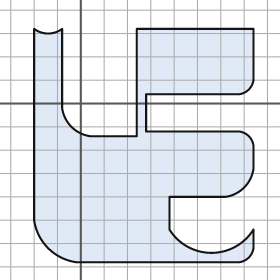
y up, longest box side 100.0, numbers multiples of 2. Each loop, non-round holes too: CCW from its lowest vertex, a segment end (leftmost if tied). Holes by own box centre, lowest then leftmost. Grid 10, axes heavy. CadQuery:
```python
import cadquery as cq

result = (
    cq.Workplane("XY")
    .moveTo(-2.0, -68.0)
    .lineTo(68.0, -68.0)
    .threePointArc((72.0, -66.0), (74.0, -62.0))
    .lineTo(74.0, -54.0)
    .threePointArc((56.0, -64.0), (38.0, -54.0))
    .lineTo(38.0, -40.0)
    .lineTo(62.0, -40.0)
    .threePointArc((70.0, -36.0), (74.0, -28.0))
    .lineTo(74.0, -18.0)
    .threePointArc((72.0, -14.0), (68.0, -12.0))
    .lineTo(28.0, -12.0)
    .lineTo(28.0, 4.0)
    .lineTo(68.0, 4.0)
    .threePointArc((72.0, 6.0), (74.0, 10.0))
    .lineTo(74.0, 32.0)
    .lineTo(24.0, 32.0)
    .lineTo(24.0, -14.0)
    .lineTo(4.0, -14.0)
    .threePointArc((-4.0, -10.0), (-8.0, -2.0))
    .lineTo(-8.0, 32.0)
    .threePointArc((-14.0, 30.0), (-20.0, 32.0))
    .lineTo(-20.0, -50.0)
    .threePointArc((-14.0, -62.0), (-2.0, -68.0))
    .close()
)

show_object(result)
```